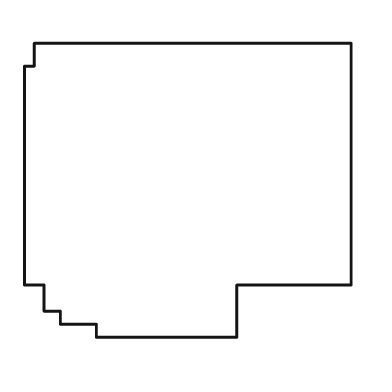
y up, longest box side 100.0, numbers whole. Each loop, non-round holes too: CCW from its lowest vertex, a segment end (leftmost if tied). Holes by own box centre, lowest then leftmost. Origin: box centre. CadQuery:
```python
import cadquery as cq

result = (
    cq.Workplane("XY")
    .moveTo(-28.0, -45.0)
    .lineTo(15.0, -45.0)
    .lineTo(15.0, -29.0)
    .lineTo(50.0, -29.0)
    .lineTo(50.0, 45.0)
    .lineTo(-47.0, 45.0)
    .lineTo(-47.0, 38.0)
    .lineTo(-50.0, 38.0)
    .lineTo(-50.0, -29.0)
    .lineTo(-44.0, -29.0)
    .lineTo(-44.0, -37.0)
    .lineTo(-39.0, -37.0)
    .lineTo(-39.0, -41.0)
    .lineTo(-28.0, -41.0)
    .close()
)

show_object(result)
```